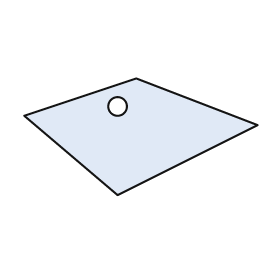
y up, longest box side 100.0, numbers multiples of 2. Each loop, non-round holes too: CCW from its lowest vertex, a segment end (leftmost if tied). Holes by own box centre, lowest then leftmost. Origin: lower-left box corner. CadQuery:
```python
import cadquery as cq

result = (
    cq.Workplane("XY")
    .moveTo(40.0, 0.0)
    .lineTo(100.0, 30.0)
    .lineTo(48.0, 50.0)
    .lineTo(0.0, 34.0)
    .close()
    .moveTo(40.0, 38.0)
    .circle(4.0)
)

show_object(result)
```